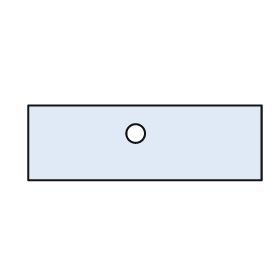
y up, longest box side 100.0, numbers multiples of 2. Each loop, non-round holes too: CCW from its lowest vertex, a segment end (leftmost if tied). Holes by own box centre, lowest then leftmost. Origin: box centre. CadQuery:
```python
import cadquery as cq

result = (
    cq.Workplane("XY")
    .moveTo(-50.0, -16.0)
    .lineTo(50.0, -16.0)
    .lineTo(50.0, 16.0)
    .lineTo(-50.0, 16.0)
    .close()
    .moveTo(-4.0, 4.0)
    .circle(4.0)
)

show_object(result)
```